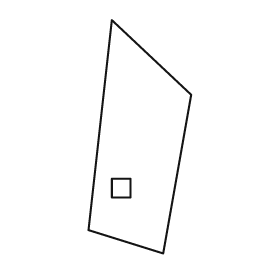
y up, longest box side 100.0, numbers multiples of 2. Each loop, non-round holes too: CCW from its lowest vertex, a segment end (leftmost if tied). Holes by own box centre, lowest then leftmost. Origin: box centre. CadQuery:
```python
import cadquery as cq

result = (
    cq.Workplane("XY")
    .moveTo(10.0, -50.0)
    .lineTo(22.0, 18.0)
    .lineTo(-12.0, 50.0)
    .lineTo(-22.0, -40.0)
    .close()
    .moveTo(-12.0, -26.0)
    .lineTo(-4.0, -26.0)
    .lineTo(-4.0, -18.0)
    .lineTo(-12.0, -18.0)
    .close()
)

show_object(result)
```